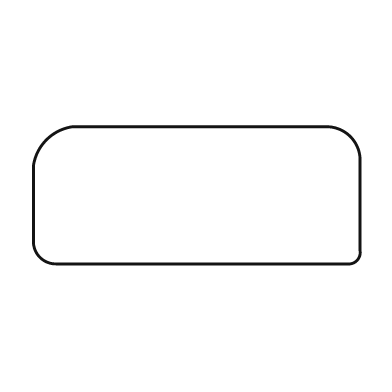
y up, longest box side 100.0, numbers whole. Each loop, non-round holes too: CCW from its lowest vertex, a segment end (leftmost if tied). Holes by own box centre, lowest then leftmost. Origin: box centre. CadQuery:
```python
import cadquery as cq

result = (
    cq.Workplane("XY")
    .moveTo(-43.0, -21.0)
    .lineTo(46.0, -21.0)
    .threePointArc((49.0, -20.0), (50.0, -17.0))
    .lineTo(50.0, 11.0)
    .threePointArc((47.0, 18.0), (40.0, 21.0))
    .lineTo(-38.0, 21.0)
    .threePointArc((-46.0, 17.0), (-50.0, 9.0))
    .lineTo(-50.0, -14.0)
    .threePointArc((-48.0, -19.0), (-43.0, -21.0))
    .close()
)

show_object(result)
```